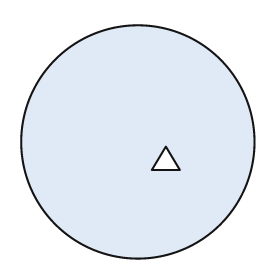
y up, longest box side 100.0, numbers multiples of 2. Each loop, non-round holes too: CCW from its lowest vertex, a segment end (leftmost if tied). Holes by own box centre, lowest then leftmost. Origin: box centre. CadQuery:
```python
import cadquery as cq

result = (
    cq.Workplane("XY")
    .moveTo(0.0, 0.0)
    .circle(50.0)
    .moveTo(6.0, -12.0)
    .lineTo(18.0, -12.0)
    .lineTo(12.0, -2.0)
    .close()
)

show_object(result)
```